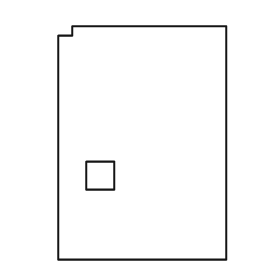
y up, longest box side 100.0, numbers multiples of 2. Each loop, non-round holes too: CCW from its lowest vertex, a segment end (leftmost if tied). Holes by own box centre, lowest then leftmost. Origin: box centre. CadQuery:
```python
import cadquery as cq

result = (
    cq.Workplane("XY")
    .moveTo(-36.0, -50.0)
    .lineTo(36.0, -50.0)
    .lineTo(36.0, 50.0)
    .lineTo(-30.0, 50.0)
    .lineTo(-30.0, 46.0)
    .lineTo(-36.0, 46.0)
    .close()
    .moveTo(-24.0, -20.0)
    .lineTo(-12.0, -20.0)
    .lineTo(-12.0, -8.0)
    .lineTo(-24.0, -8.0)
    .close()
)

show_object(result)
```